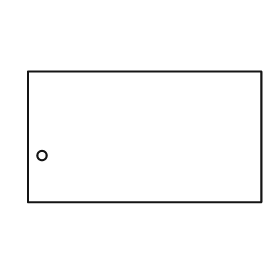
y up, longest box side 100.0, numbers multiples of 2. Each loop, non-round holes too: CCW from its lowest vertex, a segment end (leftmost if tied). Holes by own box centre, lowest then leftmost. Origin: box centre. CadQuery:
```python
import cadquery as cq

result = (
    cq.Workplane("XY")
    .moveTo(-50.0, -28.0)
    .lineTo(50.0, -28.0)
    .lineTo(50.0, 28.0)
    .lineTo(-50.0, 28.0)
    .close()
    .moveTo(-44.0, -8.0)
    .circle(2.0)
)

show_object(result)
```